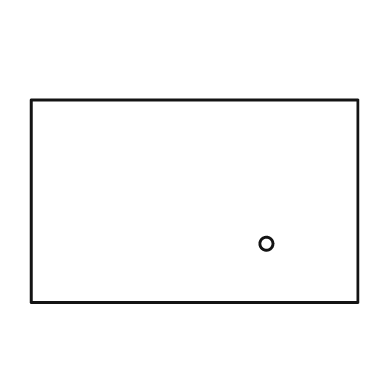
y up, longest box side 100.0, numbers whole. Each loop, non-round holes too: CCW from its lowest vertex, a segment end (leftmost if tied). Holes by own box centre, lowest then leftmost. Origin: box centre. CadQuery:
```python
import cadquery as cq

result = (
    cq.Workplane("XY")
    .moveTo(-50.0, -31.0)
    .lineTo(50.0, -31.0)
    .lineTo(50.0, 31.0)
    .lineTo(-50.0, 31.0)
    .close()
    .moveTo(22.0, -13.0)
    .circle(2.0)
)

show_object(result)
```